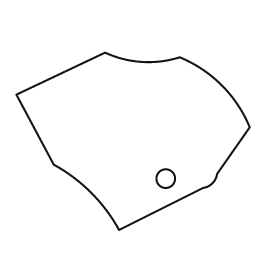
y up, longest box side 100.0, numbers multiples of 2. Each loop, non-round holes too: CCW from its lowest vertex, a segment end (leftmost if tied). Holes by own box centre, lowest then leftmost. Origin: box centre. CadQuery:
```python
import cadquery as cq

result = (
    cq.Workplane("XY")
    .moveTo(-6.0, -38.0)
    .lineTo(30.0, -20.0)
    .threePointArc((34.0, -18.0), (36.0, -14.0))
    .lineTo(50.0, 6.0)
    .threePointArc((38.0, 24.0), (20.0, 36.0))
    .threePointArc((4.0, 34.0), (-12.0, 38.0))
    .lineTo(-50.0, 20.0)
    .lineTo(-34.0, -10.0)
    .threePointArc((-18.0, -22.0), (-6.0, -38.0))
    .close()
    .moveTo(14.0, -16.0)
    .circle(4.0)
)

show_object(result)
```